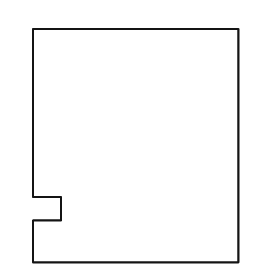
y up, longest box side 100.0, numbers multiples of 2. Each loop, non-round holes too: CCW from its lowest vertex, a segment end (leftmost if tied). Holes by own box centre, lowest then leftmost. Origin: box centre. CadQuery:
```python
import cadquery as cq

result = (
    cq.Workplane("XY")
    .moveTo(-44.0, -50.0)
    .lineTo(44.0, -50.0)
    .lineTo(44.0, 50.0)
    .lineTo(-44.0, 50.0)
    .lineTo(-44.0, -22.0)
    .lineTo(-32.0, -22.0)
    .lineTo(-32.0, -32.0)
    .lineTo(-44.0, -32.0)
    .close()
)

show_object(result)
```